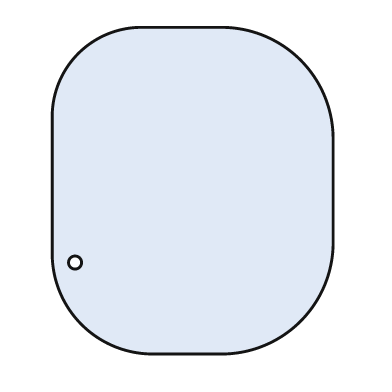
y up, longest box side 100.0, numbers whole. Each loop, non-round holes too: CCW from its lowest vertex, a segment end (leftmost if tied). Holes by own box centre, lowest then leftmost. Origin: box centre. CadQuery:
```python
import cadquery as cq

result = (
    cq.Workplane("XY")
    .moveTo(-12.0, -50.0)
    .lineTo(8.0, -50.0)
    .threePointArc((33.0, -40.0), (43.0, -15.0))
    .lineTo(43.0, 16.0)
    .threePointArc((33.0, 40.0), (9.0, 50.0))
    .lineTo(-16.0, 50.0)
    .threePointArc((-35.0, 42.0), (-43.0, 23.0))
    .lineTo(-43.0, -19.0)
    .threePointArc((-34.0, -41.0), (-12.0, -50.0))
    .close()
    .moveTo(-36.0, -22.0)
    .circle(2.0)
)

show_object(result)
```